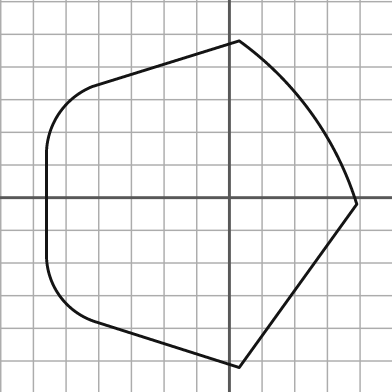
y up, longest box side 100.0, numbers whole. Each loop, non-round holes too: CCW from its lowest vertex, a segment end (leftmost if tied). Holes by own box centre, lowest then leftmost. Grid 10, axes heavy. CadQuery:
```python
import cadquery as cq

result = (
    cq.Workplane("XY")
    .moveTo(3.0, -52.0)
    .lineTo(39.0, -2.0)
    .threePointArc((25.0, 26.0), (3.0, 48.0))
    .lineTo(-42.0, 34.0)
    .threePointArc((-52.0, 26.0), (-56.0, 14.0))
    .lineTo(-56.0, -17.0)
    .threePointArc((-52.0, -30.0), (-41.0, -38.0))
    .close()
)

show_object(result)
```